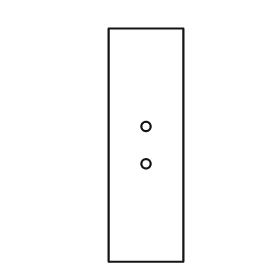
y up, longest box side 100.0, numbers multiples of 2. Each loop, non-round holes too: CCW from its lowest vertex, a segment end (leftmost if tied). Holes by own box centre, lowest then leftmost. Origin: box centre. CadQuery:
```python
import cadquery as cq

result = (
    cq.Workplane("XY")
    .moveTo(-16.0, -50.0)
    .lineTo(16.0, -50.0)
    .lineTo(16.0, 50.0)
    .lineTo(-16.0, 50.0)
    .close()
    .moveTo(0.0, -8.0)
    .circle(2.0)
    .moveTo(0.0, 8.0)
    .circle(2.0)
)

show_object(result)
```